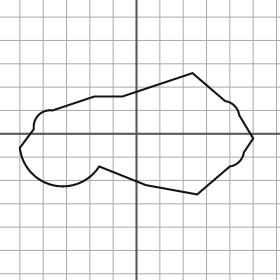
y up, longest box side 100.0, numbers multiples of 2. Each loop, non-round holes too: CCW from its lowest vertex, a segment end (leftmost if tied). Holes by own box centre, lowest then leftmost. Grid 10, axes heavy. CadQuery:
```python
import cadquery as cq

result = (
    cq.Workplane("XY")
    .moveTo(26.0, -26.0)
    .lineTo(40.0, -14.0)
    .threePointArc((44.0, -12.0), (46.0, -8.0))
    .lineTo(50.0, -2.0)
    .lineTo(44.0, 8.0)
    .threePointArc((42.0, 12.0), (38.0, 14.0))
    .lineTo(24.0, 26.0)
    .lineTo(-6.0, 16.0)
    .lineTo(-18.0, 16.0)
    .lineTo(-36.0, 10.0)
    .threePointArc((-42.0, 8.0), (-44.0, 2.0))
    .lineTo(-50.0, -6.0)
    .threePointArc((-36.0, -22.0), (-16.0, -14.0))
    .lineTo(4.0, -22.0)
    .close()
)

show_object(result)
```